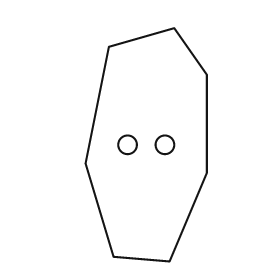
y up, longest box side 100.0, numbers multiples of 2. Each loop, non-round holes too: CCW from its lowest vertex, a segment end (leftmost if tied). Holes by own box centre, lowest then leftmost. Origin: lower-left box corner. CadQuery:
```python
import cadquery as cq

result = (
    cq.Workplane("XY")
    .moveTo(36.0, 0.0)
    .lineTo(52.0, 38.0)
    .lineTo(52.0, 80.0)
    .lineTo(38.0, 100.0)
    .lineTo(10.0, 92.0)
    .lineTo(0.0, 42.0)
    .lineTo(12.0, 2.0)
    .close()
    .moveTo(18.0, 50.0)
    .circle(4.0)
    .moveTo(34.0, 50.0)
    .circle(4.0)
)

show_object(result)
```